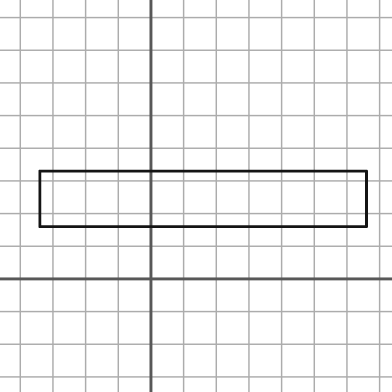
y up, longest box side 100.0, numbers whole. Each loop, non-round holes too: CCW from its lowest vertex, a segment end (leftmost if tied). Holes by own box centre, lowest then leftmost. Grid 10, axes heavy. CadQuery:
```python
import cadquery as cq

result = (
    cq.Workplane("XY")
    .moveTo(-34.0, 16.0)
    .lineTo(66.0, 16.0)
    .lineTo(66.0, 33.0)
    .lineTo(-34.0, 33.0)
    .close()
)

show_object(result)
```